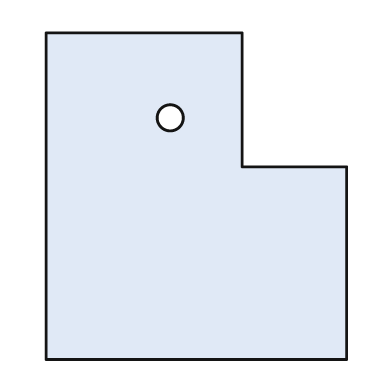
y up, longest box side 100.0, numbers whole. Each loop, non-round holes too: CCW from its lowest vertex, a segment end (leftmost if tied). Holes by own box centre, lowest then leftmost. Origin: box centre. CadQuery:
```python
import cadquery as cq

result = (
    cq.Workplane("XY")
    .moveTo(-46.0, -50.0)
    .lineTo(46.0, -50.0)
    .lineTo(46.0, 9.0)
    .lineTo(14.0, 9.0)
    .lineTo(14.0, 50.0)
    .lineTo(-46.0, 50.0)
    .close()
    .moveTo(-8.0, 24.0)
    .circle(4.0)
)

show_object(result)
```